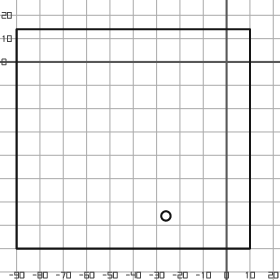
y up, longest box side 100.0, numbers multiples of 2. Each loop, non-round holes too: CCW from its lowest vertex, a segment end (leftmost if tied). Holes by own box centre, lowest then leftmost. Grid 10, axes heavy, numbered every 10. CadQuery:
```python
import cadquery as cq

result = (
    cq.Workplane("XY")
    .moveTo(-90.0, -80.0)
    .lineTo(10.0, -80.0)
    .lineTo(10.0, 14.0)
    .lineTo(-90.0, 14.0)
    .close()
    .moveTo(-26.0, -66.0)
    .circle(2.0)
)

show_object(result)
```